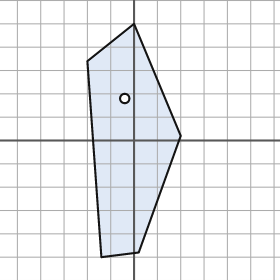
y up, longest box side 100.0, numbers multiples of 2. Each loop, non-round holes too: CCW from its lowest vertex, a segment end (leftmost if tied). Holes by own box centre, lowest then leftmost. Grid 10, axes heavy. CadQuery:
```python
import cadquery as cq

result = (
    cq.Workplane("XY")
    .moveTo(-14.0, -50.0)
    .lineTo(2.0, -48.0)
    .lineTo(20.0, 2.0)
    .lineTo(0.0, 50.0)
    .lineTo(-20.0, 34.0)
    .close()
    .moveTo(-4.0, 18.0)
    .circle(2.0)
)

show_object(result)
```